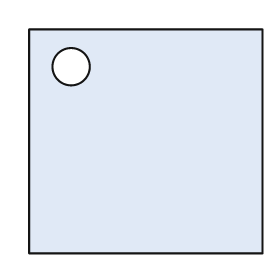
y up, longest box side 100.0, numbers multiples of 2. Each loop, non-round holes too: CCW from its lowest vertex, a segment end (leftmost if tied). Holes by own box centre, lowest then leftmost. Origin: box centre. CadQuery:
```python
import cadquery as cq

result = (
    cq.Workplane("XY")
    .moveTo(-50.0, -48.0)
    .lineTo(50.0, -48.0)
    .lineTo(50.0, 48.0)
    .lineTo(-50.0, 48.0)
    .close()
    .moveTo(-32.0, 32.0)
    .circle(8.0)
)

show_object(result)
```